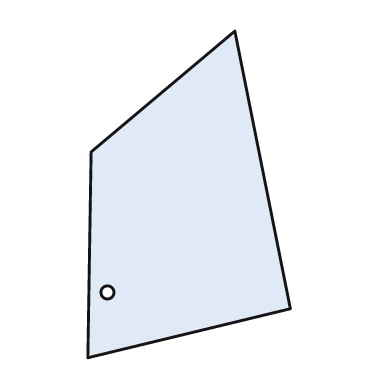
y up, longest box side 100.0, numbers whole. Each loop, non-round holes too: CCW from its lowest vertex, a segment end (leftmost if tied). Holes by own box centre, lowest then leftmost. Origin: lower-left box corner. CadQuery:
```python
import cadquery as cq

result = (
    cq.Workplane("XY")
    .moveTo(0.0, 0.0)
    .lineTo(62.0, 15.0)
    .lineTo(45.0, 100.0)
    .lineTo(1.0, 63.0)
    .close()
    .moveTo(6.0, 20.0)
    .circle(2.0)
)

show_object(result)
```